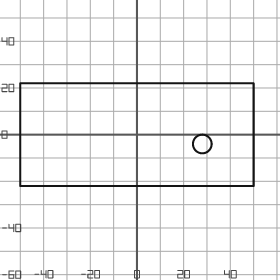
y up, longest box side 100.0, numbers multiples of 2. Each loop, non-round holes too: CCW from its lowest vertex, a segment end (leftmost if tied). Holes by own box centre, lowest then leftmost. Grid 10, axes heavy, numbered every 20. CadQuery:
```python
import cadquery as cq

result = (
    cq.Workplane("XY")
    .moveTo(-50.0, -22.0)
    .lineTo(50.0, -22.0)
    .lineTo(50.0, 22.0)
    .lineTo(-50.0, 22.0)
    .close()
    .moveTo(28.0, -4.0)
    .circle(4.0)
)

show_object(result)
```